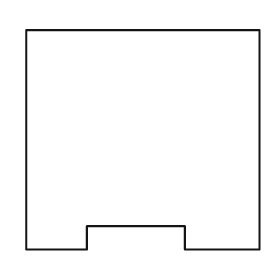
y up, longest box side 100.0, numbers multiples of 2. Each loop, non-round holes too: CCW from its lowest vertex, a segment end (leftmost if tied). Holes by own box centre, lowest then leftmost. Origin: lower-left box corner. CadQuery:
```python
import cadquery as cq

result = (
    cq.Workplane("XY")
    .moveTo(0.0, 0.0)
    .lineTo(26.0, 0.0)
    .lineTo(26.0, 10.0)
    .lineTo(68.0, 10.0)
    .lineTo(68.0, 0.0)
    .lineTo(100.0, 0.0)
    .lineTo(100.0, 94.0)
    .lineTo(0.0, 94.0)
    .close()
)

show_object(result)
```